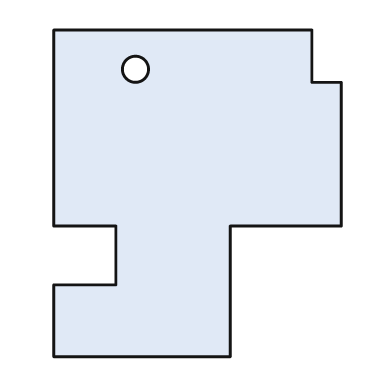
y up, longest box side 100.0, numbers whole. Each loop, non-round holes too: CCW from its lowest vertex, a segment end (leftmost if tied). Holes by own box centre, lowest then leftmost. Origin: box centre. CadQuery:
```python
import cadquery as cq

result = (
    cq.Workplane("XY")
    .moveTo(-44.0, -50.0)
    .lineTo(10.0, -50.0)
    .lineTo(10.0, -10.0)
    .lineTo(44.0, -10.0)
    .lineTo(44.0, 34.0)
    .lineTo(35.0, 34.0)
    .lineTo(35.0, 50.0)
    .lineTo(-44.0, 50.0)
    .lineTo(-44.0, -10.0)
    .lineTo(-25.0, -10.0)
    .lineTo(-25.0, -28.0)
    .lineTo(-44.0, -28.0)
    .close()
    .moveTo(-19.0, 38.0)
    .circle(4.0)
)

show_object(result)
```